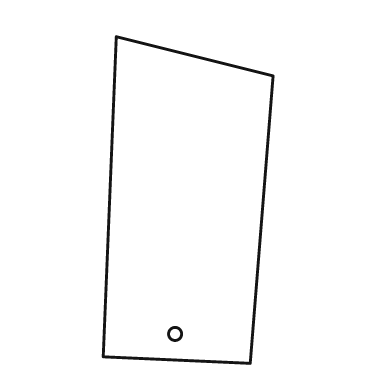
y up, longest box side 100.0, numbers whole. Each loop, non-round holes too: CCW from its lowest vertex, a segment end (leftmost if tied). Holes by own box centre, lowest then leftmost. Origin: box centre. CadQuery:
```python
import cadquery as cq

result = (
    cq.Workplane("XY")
    .moveTo(19.0, -50.0)
    .lineTo(26.0, 38.0)
    .lineTo(-22.0, 50.0)
    .lineTo(-26.0, -48.0)
    .close()
    .moveTo(-4.0, -41.0)
    .circle(2.0)
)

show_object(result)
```